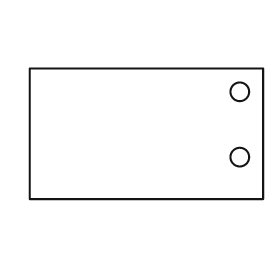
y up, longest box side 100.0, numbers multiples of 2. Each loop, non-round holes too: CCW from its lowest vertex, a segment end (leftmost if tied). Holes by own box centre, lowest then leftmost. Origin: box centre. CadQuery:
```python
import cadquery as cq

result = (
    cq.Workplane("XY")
    .moveTo(-50.0, -28.0)
    .lineTo(50.0, -28.0)
    .lineTo(50.0, 28.0)
    .lineTo(-50.0, 28.0)
    .close()
    .moveTo(40.0, -10.0)
    .circle(4.0)
    .moveTo(40.0, 18.0)
    .circle(4.0)
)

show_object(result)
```